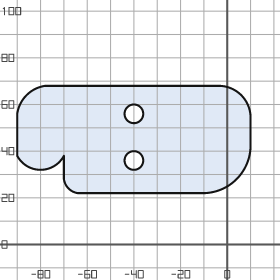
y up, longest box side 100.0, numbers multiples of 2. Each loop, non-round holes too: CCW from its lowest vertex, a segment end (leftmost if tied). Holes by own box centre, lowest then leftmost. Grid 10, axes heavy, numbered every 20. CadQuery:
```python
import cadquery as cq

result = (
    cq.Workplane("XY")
    .moveTo(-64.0, 22.0)
    .lineTo(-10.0, 22.0)
    .threePointArc((4.0, 28.0), (10.0, 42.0))
    .lineTo(10.0, 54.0)
    .threePointArc((6.0, 64.0), (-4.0, 68.0))
    .lineTo(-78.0, 68.0)
    .threePointArc((-86.0, 64.0), (-90.0, 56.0))
    .lineTo(-90.0, 38.0)
    .threePointArc((-80.0, 32.0), (-70.0, 38.0))
    .lineTo(-70.0, 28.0)
    .threePointArc((-68.0, 24.0), (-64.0, 22.0))
    .close()
    .moveTo(-40.0, 36.0)
    .circle(4.0)
    .moveTo(-40.0, 56.0)
    .circle(4.0)
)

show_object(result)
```